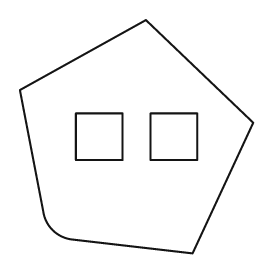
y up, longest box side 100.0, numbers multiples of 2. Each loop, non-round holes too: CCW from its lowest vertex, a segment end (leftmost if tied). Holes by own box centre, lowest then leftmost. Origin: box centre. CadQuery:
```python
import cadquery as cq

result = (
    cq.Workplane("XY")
    .moveTo(24.0, -50.0)
    .lineTo(50.0, 6.0)
    .lineTo(4.0, 50.0)
    .lineTo(-50.0, 20.0)
    .lineTo(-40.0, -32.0)
    .threePointArc((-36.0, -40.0), (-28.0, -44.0))
    .close()
    .moveTo(-26.0, -10.0)
    .lineTo(-6.0, -10.0)
    .lineTo(-6.0, 10.0)
    .lineTo(-26.0, 10.0)
    .close()
    .moveTo(6.0, -10.0)
    .lineTo(26.0, -10.0)
    .lineTo(26.0, 10.0)
    .lineTo(6.0, 10.0)
    .close()
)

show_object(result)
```